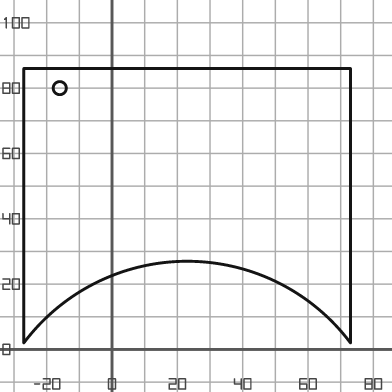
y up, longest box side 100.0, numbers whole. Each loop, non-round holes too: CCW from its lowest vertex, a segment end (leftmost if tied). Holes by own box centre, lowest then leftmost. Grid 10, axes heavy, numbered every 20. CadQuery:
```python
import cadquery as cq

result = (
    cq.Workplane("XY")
    .moveTo(-27.0, 2.0)
    .threePointArc((23.0, 27.0), (73.0, 2.0))
    .lineTo(73.0, 86.0)
    .lineTo(-27.0, 86.0)
    .close()
    .moveTo(-16.0, 80.0)
    .circle(2.0)
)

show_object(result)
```